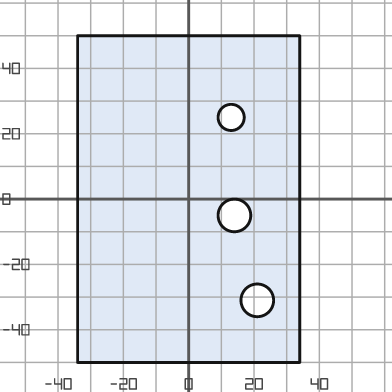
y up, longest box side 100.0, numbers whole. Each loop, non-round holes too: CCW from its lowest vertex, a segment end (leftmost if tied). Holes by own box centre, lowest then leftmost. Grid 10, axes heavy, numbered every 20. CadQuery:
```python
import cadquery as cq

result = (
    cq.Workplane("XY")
    .moveTo(-34.0, -50.0)
    .lineTo(34.0, -50.0)
    .lineTo(34.0, 50.0)
    .lineTo(-34.0, 50.0)
    .close()
    .moveTo(21.0, -31.0)
    .circle(5.0)
    .moveTo(14.0, -5.0)
    .circle(5.0)
    .moveTo(13.0, 25.0)
    .circle(4.0)
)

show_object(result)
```